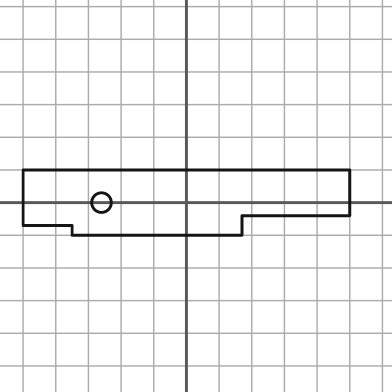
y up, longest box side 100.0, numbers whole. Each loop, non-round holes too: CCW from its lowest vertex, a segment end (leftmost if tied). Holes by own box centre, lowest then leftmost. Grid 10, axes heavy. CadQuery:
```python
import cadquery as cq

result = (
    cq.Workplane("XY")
    .moveTo(-35.0, -10.0)
    .lineTo(17.0, -10.0)
    .lineTo(17.0, -4.0)
    .lineTo(50.0, -4.0)
    .lineTo(50.0, 10.0)
    .lineTo(-50.0, 10.0)
    .lineTo(-50.0, -7.0)
    .lineTo(-35.0, -7.0)
    .close()
    .moveTo(-26.0, 0.0)
    .circle(3.0)
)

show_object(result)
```